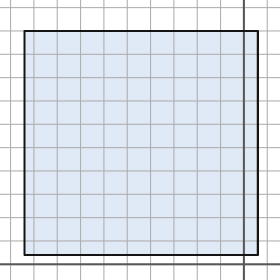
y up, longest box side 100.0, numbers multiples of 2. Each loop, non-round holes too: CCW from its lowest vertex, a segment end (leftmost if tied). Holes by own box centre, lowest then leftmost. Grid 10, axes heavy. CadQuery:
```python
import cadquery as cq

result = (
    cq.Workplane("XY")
    .moveTo(-94.0, 4.0)
    .lineTo(6.0, 4.0)
    .lineTo(6.0, 100.0)
    .lineTo(-94.0, 100.0)
    .close()
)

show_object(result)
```